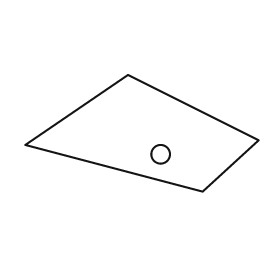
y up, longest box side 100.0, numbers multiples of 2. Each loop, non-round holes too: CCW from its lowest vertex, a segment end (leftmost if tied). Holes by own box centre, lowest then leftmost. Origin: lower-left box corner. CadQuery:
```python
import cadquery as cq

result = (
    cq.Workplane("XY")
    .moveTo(76.0, 0.0)
    .lineTo(100.0, 22.0)
    .lineTo(44.0, 50.0)
    .lineTo(0.0, 20.0)
    .close()
    .moveTo(58.0, 16.0)
    .circle(4.0)
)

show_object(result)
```